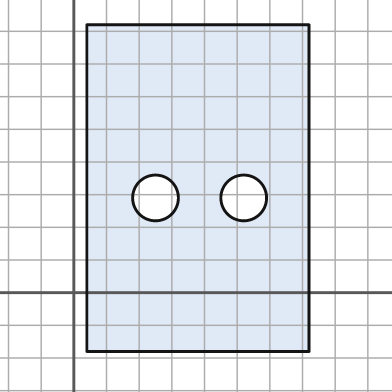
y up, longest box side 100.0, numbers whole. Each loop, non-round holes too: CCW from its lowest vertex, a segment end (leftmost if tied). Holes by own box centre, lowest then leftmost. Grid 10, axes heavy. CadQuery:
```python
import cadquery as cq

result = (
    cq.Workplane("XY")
    .moveTo(4.0, -18.0)
    .lineTo(72.0, -18.0)
    .lineTo(72.0, 82.0)
    .lineTo(4.0, 82.0)
    .close()
    .moveTo(25.0, 29.0)
    .circle(7.0)
    .moveTo(52.0, 29.0)
    .circle(7.0)
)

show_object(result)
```